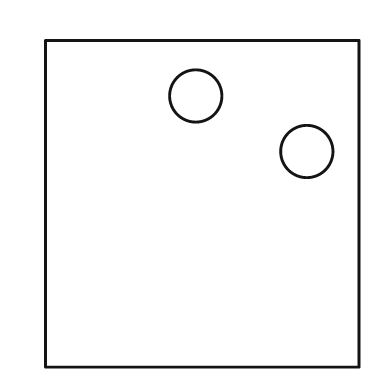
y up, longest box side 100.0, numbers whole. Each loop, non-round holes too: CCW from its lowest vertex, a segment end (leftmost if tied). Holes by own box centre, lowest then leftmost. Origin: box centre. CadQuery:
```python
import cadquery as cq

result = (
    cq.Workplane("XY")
    .moveTo(-48.0, -50.0)
    .lineTo(48.0, -50.0)
    .lineTo(48.0, 50.0)
    .lineTo(-48.0, 50.0)
    .close()
    .moveTo(32.0, 16.0)
    .circle(8.0)
    .moveTo(-2.0, 33.0)
    .circle(8.0)
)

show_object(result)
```